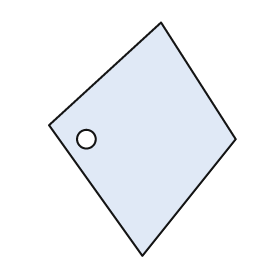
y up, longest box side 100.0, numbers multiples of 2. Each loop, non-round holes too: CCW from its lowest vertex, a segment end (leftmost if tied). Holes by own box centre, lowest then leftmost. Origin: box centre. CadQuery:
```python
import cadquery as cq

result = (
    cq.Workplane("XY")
    .moveTo(0.0, -50.0)
    .lineTo(40.0, 0.0)
    .lineTo(8.0, 50.0)
    .lineTo(-40.0, 6.0)
    .close()
    .moveTo(-24.0, 0.0)
    .circle(4.0)
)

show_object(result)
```